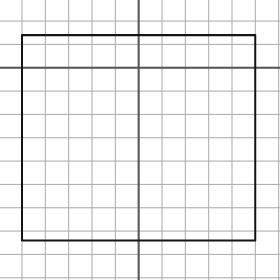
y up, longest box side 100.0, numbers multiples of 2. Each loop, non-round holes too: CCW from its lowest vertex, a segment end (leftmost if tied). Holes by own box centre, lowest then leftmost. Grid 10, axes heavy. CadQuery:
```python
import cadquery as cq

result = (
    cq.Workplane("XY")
    .moveTo(-50.0, -74.0)
    .lineTo(50.0, -74.0)
    .lineTo(50.0, 14.0)
    .lineTo(-50.0, 14.0)
    .close()
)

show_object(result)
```